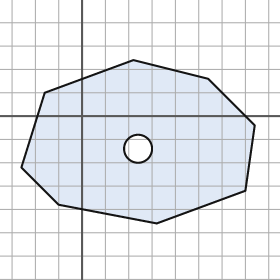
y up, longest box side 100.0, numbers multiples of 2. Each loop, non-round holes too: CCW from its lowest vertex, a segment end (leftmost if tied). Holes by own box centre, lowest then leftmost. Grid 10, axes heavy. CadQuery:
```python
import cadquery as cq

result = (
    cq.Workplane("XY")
    .moveTo(32.0, -46.0)
    .lineTo(70.0, -32.0)
    .lineTo(74.0, -4.0)
    .lineTo(54.0, 16.0)
    .lineTo(22.0, 24.0)
    .lineTo(-16.0, 10.0)
    .lineTo(-26.0, -22.0)
    .lineTo(-10.0, -38.0)
    .close()
    .moveTo(24.0, -14.0)
    .circle(6.0)
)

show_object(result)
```